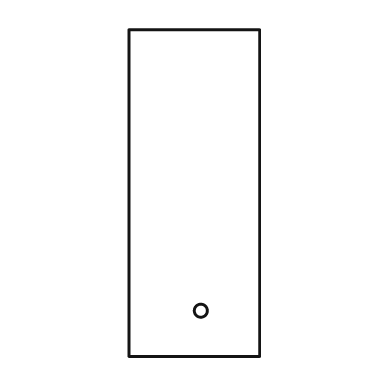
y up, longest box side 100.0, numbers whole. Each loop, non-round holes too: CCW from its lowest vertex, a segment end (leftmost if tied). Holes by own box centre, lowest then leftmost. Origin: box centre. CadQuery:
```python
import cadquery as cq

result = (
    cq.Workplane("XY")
    .moveTo(-20.0, -50.0)
    .lineTo(20.0, -50.0)
    .lineTo(20.0, 50.0)
    .lineTo(-20.0, 50.0)
    .close()
    .moveTo(2.0, -36.0)
    .circle(2.0)
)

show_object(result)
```